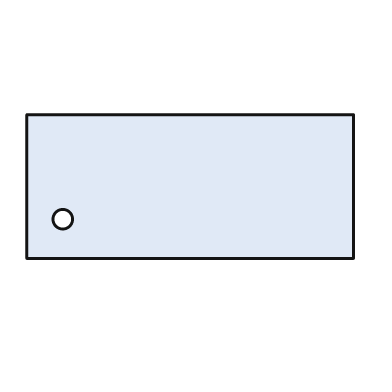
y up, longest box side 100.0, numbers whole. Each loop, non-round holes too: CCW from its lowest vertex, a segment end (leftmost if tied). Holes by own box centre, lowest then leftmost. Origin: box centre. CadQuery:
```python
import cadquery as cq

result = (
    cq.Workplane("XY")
    .moveTo(-50.0, -22.0)
    .lineTo(50.0, -22.0)
    .lineTo(50.0, 22.0)
    .lineTo(-50.0, 22.0)
    .close()
    .moveTo(-39.0, -10.0)
    .circle(3.0)
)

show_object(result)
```